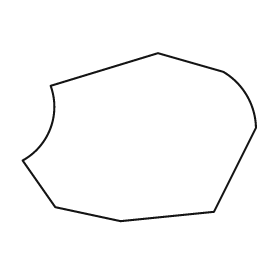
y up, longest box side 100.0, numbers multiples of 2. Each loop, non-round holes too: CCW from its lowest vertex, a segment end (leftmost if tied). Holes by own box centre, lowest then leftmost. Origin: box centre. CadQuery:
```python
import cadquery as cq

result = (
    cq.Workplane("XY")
    .moveTo(-8.0, -36.0)
    .lineTo(32.0, -32.0)
    .lineTo(50.0, 4.0)
    .threePointArc((46.0, 18.0), (36.0, 28.0))
    .lineTo(8.0, 36.0)
    .lineTo(-38.0, 22.0)
    .threePointArc((-38.0, 4.0), (-50.0, -10.0))
    .lineTo(-36.0, -30.0)
    .close()
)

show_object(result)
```